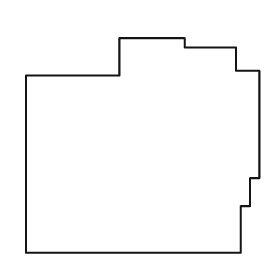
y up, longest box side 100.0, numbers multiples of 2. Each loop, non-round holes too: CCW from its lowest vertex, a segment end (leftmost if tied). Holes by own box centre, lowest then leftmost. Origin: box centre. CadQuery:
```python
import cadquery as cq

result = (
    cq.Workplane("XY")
    .moveTo(-50.0, -46.0)
    .lineTo(42.0, -46.0)
    .lineTo(42.0, -26.0)
    .lineTo(46.0, -26.0)
    .lineTo(46.0, -14.0)
    .lineTo(50.0, -14.0)
    .lineTo(50.0, 32.0)
    .lineTo(40.0, 32.0)
    .lineTo(40.0, 42.0)
    .lineTo(18.0, 42.0)
    .lineTo(18.0, 46.0)
    .lineTo(-10.0, 46.0)
    .lineTo(-10.0, 30.0)
    .lineTo(-50.0, 30.0)
    .close()
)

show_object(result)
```